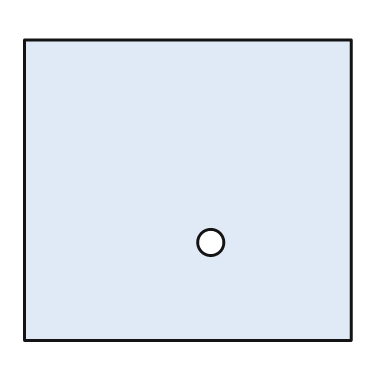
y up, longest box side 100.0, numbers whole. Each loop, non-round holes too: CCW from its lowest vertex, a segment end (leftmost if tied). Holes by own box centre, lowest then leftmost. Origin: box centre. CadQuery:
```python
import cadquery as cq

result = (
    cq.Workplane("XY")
    .moveTo(-50.0, -46.0)
    .lineTo(50.0, -46.0)
    .lineTo(50.0, 46.0)
    .lineTo(-50.0, 46.0)
    .close()
    .moveTo(7.0, -16.0)
    .circle(4.0)
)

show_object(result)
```